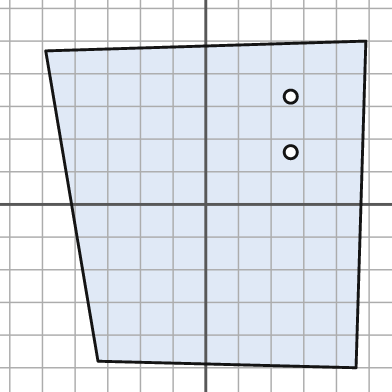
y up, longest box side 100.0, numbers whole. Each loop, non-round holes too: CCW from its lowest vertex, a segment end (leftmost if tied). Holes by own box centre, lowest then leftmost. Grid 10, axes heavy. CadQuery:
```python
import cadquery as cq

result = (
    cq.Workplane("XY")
    .moveTo(46.0, -50.0)
    .lineTo(49.0, 50.0)
    .lineTo(-49.0, 47.0)
    .lineTo(-33.0, -48.0)
    .close()
    .moveTo(26.0, 16.0)
    .circle(2.0)
    .moveTo(26.0, 33.0)
    .circle(2.0)
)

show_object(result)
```